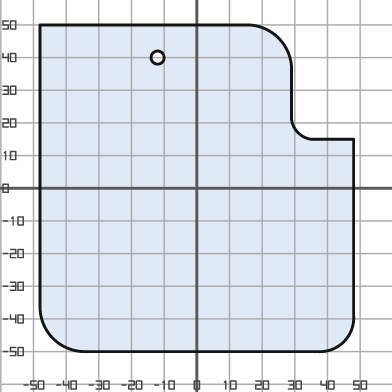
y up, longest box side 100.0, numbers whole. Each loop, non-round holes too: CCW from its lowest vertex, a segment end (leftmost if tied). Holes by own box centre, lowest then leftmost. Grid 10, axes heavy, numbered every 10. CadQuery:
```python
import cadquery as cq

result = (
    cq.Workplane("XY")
    .moveTo(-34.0, -50.0)
    .lineTo(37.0, -50.0)
    .threePointArc((45.0, -47.0), (48.0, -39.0))
    .lineTo(48.0, 15.0)
    .lineTo(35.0, 15.0)
    .threePointArc((31.0, 17.0), (29.0, 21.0))
    .lineTo(29.0, 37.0)
    .threePointArc((25.0, 46.0), (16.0, 50.0))
    .lineTo(-48.0, 50.0)
    .lineTo(-48.0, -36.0)
    .threePointArc((-44.0, -46.0), (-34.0, -50.0))
    .close()
    .moveTo(-12.0, 40.0)
    .circle(2.0)
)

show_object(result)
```